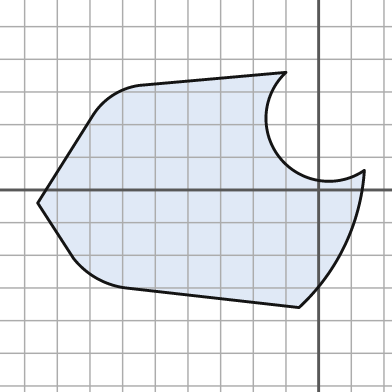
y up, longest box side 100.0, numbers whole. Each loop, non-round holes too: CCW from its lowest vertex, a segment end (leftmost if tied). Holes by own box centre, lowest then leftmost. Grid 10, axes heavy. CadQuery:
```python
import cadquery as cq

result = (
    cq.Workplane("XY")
    .moveTo(-6.0, -36.0)
    .threePointArc((8.0, -17.0), (14.0, 6.0))
    .threePointArc((-12.0, 10.0), (-10.0, 36.0))
    .lineTo(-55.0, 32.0)
    .threePointArc((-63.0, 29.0), (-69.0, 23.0))
    .lineTo(-86.0, -4.0)
    .lineTo(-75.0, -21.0)
    .threePointArc((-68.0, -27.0), (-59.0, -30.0))
    .close()
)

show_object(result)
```